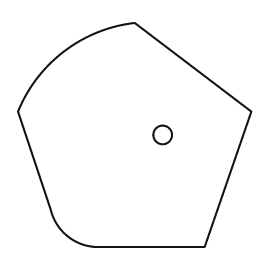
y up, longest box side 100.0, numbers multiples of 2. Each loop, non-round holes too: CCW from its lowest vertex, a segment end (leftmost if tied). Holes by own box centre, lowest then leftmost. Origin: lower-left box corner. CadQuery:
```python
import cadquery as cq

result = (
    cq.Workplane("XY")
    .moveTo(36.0, 0.0)
    .lineTo(80.0, 0.0)
    .lineTo(100.0, 58.0)
    .lineTo(50.0, 96.0)
    .threePointArc((20.0, 84.0), (0.0, 58.0))
    .lineTo(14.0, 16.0)
    .threePointArc((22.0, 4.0), (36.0, 0.0))
    .close()
    .moveTo(62.0, 48.0)
    .circle(4.0)
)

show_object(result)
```